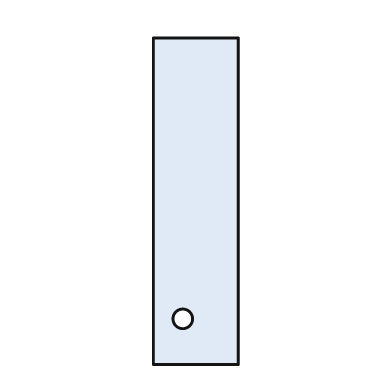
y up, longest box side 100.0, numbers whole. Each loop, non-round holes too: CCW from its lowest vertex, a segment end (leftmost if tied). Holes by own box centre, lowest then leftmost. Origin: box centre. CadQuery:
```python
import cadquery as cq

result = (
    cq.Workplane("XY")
    .moveTo(-13.0, -50.0)
    .lineTo(13.0, -50.0)
    .lineTo(13.0, 50.0)
    .lineTo(-13.0, 50.0)
    .close()
    .moveTo(-4.0, -36.0)
    .circle(3.0)
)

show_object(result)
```